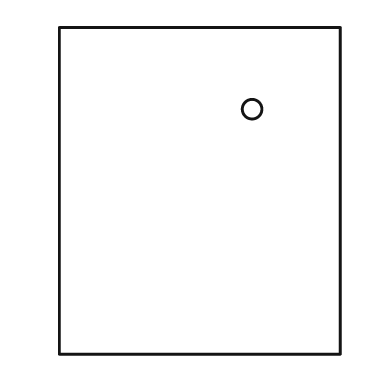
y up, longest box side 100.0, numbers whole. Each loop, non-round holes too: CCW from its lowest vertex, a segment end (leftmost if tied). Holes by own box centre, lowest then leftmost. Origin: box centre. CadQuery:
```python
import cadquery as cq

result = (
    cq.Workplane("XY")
    .moveTo(-43.0, -50.0)
    .lineTo(43.0, -50.0)
    .lineTo(43.0, 50.0)
    .lineTo(-43.0, 50.0)
    .close()
    .moveTo(16.0, 25.0)
    .circle(3.0)
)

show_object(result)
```